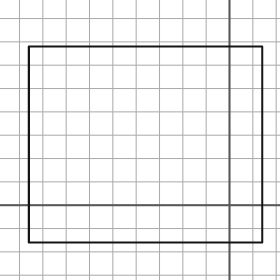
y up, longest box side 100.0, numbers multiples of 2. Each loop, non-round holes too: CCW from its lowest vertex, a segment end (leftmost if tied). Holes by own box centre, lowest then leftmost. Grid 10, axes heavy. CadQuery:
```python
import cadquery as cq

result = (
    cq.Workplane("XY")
    .moveTo(-86.0, -16.0)
    .lineTo(14.0, -16.0)
    .lineTo(14.0, 68.0)
    .lineTo(-86.0, 68.0)
    .close()
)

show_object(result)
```